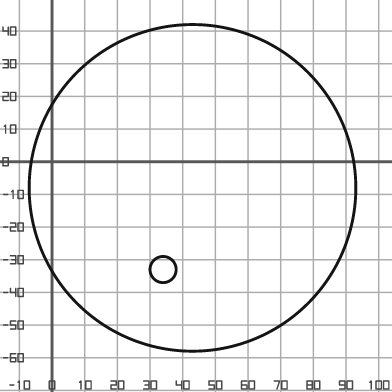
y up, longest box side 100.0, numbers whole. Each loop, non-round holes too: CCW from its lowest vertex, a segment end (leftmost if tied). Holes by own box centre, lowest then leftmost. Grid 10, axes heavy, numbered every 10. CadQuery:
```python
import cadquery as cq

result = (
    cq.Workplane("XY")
    .moveTo(43.0, -8.0)
    .circle(50.0)
    .moveTo(34.0, -33.0)
    .circle(4.0)
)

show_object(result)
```